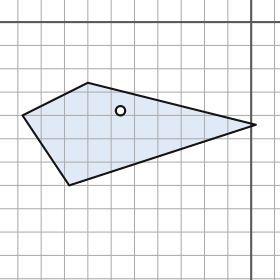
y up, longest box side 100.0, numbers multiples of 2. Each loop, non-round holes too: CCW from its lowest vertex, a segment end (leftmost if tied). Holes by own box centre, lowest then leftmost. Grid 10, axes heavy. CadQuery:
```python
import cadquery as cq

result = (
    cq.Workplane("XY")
    .moveTo(-78.0, -70.0)
    .lineTo(2.0, -44.0)
    .lineTo(-70.0, -26.0)
    .lineTo(-98.0, -40.0)
    .close()
    .moveTo(-56.0, -38.0)
    .circle(2.0)
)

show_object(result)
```